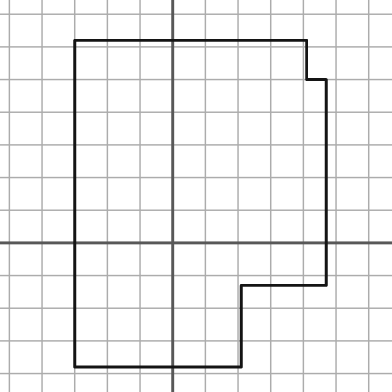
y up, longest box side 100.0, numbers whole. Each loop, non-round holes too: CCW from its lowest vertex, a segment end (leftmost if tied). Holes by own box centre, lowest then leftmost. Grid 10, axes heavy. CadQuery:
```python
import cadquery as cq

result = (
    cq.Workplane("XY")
    .moveTo(-30.0, -38.0)
    .lineTo(21.0, -38.0)
    .lineTo(21.0, -13.0)
    .lineTo(47.0, -13.0)
    .lineTo(47.0, 50.0)
    .lineTo(41.0, 50.0)
    .lineTo(41.0, 62.0)
    .lineTo(-30.0, 62.0)
    .close()
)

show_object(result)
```